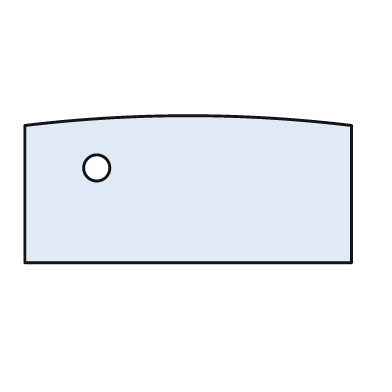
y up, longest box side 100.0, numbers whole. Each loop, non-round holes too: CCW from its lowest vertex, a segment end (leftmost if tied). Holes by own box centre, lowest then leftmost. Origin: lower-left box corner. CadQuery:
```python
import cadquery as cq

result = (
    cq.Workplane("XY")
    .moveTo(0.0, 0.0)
    .lineTo(100.0, 0.0)
    .lineTo(100.0, 42.0)
    .threePointArc((50.0, 45.0), (0.0, 42.0))
    .close()
    .moveTo(22.0, 29.0)
    .circle(4.0)
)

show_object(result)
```